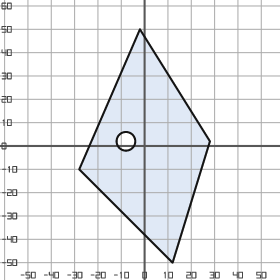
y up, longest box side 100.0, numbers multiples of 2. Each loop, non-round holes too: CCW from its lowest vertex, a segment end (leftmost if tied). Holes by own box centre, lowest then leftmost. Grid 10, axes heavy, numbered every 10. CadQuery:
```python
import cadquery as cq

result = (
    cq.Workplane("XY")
    .moveTo(12.0, -50.0)
    .lineTo(28.0, 2.0)
    .lineTo(-2.0, 50.0)
    .lineTo(-28.0, -10.0)
    .close()
    .moveTo(-8.0, 2.0)
    .circle(4.0)
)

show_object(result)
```